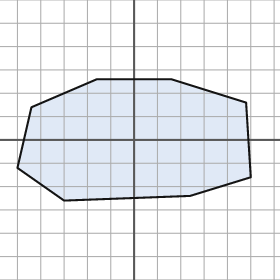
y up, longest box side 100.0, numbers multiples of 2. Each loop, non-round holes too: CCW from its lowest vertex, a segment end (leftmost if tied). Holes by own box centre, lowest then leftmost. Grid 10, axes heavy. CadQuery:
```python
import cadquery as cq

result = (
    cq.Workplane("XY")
    .moveTo(-30.0, -26.0)
    .lineTo(24.0, -24.0)
    .lineTo(50.0, -16.0)
    .lineTo(48.0, 16.0)
    .lineTo(16.0, 26.0)
    .lineTo(-16.0, 26.0)
    .lineTo(-44.0, 14.0)
    .lineTo(-50.0, -12.0)
    .close()
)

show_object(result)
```